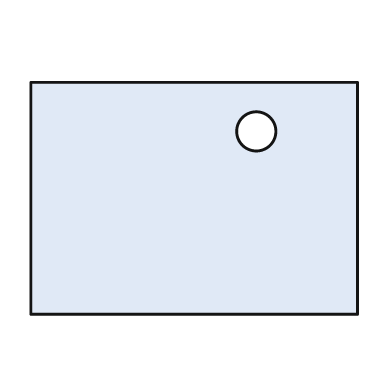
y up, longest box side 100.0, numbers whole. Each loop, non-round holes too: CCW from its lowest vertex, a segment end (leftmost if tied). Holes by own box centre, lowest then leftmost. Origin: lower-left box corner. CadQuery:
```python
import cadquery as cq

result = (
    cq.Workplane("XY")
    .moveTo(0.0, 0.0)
    .lineTo(100.0, 0.0)
    .lineTo(100.0, 71.0)
    .lineTo(0.0, 71.0)
    .close()
    .moveTo(69.0, 56.0)
    .circle(6.0)
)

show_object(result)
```